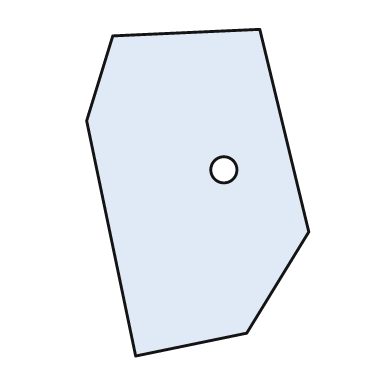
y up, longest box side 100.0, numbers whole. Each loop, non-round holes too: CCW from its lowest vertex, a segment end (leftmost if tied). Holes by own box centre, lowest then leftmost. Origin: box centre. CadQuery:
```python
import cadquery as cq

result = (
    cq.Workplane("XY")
    .moveTo(-19.0, -50.0)
    .lineTo(15.0, -43.0)
    .lineTo(34.0, -12.0)
    .lineTo(19.0, 50.0)
    .lineTo(-26.0, 48.0)
    .lineTo(-34.0, 22.0)
    .close()
    .moveTo(8.0, 7.0)
    .circle(4.0)
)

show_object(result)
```